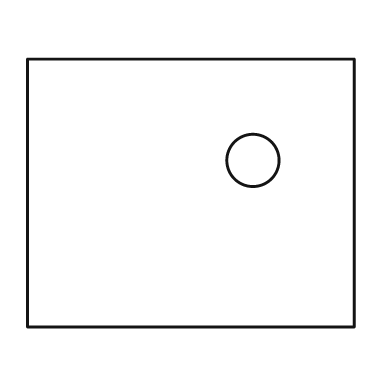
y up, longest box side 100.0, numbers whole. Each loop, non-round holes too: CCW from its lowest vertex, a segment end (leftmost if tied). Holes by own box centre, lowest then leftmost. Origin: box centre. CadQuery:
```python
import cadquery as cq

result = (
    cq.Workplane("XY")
    .moveTo(-50.0, -41.0)
    .lineTo(50.0, -41.0)
    .lineTo(50.0, 41.0)
    .lineTo(-50.0, 41.0)
    .close()
    .moveTo(19.0, 10.0)
    .circle(8.0)
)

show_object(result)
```